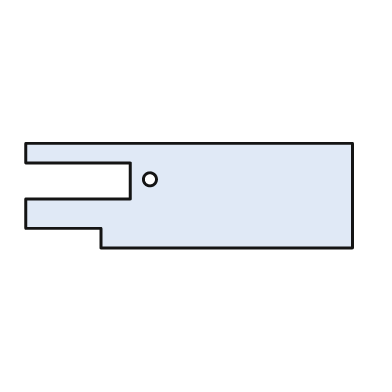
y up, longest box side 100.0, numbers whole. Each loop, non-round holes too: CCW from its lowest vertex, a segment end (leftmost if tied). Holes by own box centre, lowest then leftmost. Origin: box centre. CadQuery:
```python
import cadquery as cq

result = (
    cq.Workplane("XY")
    .moveTo(-27.0, -16.0)
    .lineTo(50.0, -16.0)
    .lineTo(50.0, 16.0)
    .lineTo(-50.0, 16.0)
    .lineTo(-50.0, 10.0)
    .lineTo(-18.0, 10.0)
    .lineTo(-18.0, -1.0)
    .lineTo(-50.0, -1.0)
    .lineTo(-50.0, -10.0)
    .lineTo(-27.0, -10.0)
    .close()
    .moveTo(-12.0, 5.0)
    .circle(2.0)
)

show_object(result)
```